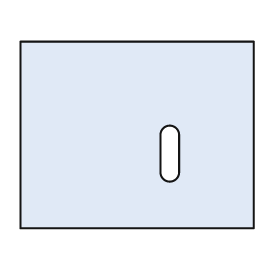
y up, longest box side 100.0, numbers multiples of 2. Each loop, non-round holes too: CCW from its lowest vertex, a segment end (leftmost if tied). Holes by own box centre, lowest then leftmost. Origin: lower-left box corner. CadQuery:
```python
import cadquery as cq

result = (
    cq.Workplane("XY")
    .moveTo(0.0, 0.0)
    .lineTo(100.0, 0.0)
    .lineTo(100.0, 80.0)
    .lineTo(0.0, 80.0)
    .close()
    .moveTo(60.0, 24.0)
    .threePointArc((64.0, 20.0), (68.0, 24.0))
    .lineTo(68.0, 40.0)
    .threePointArc((64.0, 44.0), (60.0, 40.0))
    .close()
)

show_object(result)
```